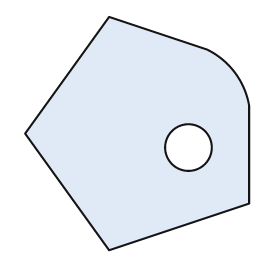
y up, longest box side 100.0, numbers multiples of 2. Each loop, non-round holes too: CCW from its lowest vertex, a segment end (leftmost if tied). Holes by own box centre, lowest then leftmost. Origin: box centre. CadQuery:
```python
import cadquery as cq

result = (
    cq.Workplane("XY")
    .moveTo(-12.0, -50.0)
    .lineTo(48.0, -30.0)
    .lineTo(48.0, 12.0)
    .threePointArc((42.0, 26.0), (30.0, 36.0))
    .lineTo(-12.0, 50.0)
    .lineTo(-48.0, 0.0)
    .close()
    .moveTo(22.0, -6.0)
    .circle(10.0)
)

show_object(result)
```